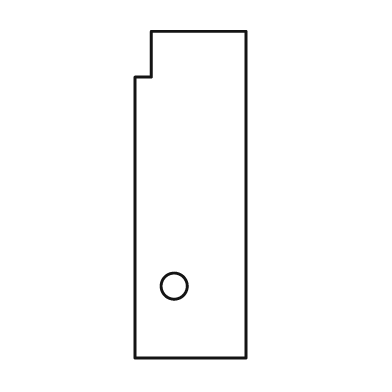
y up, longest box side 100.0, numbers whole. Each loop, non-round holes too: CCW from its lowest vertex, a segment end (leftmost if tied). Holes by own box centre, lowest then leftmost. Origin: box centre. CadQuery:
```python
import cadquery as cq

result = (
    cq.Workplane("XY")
    .moveTo(-17.0, -50.0)
    .lineTo(17.0, -50.0)
    .lineTo(17.0, 50.0)
    .lineTo(-12.0, 50.0)
    .lineTo(-12.0, 36.0)
    .lineTo(-17.0, 36.0)
    .close()
    .moveTo(-5.0, -28.0)
    .circle(4.0)
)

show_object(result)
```